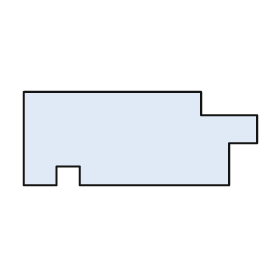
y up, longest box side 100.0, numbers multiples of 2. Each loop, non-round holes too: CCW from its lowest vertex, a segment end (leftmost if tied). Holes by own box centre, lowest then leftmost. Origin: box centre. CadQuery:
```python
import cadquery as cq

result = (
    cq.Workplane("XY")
    .moveTo(-50.0, -20.0)
    .lineTo(-36.0, -20.0)
    .lineTo(-36.0, -12.0)
    .lineTo(-26.0, -12.0)
    .lineTo(-26.0, -20.0)
    .lineTo(38.0, -20.0)
    .lineTo(38.0, -2.0)
    .lineTo(50.0, -2.0)
    .lineTo(50.0, 10.0)
    .lineTo(26.0, 10.0)
    .lineTo(26.0, 20.0)
    .lineTo(-50.0, 20.0)
    .close()
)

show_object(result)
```